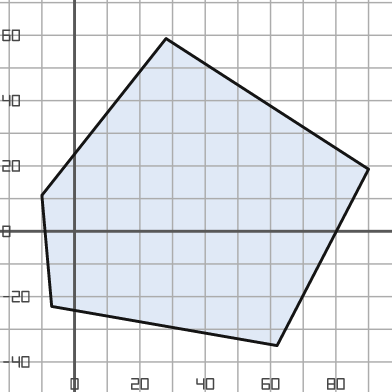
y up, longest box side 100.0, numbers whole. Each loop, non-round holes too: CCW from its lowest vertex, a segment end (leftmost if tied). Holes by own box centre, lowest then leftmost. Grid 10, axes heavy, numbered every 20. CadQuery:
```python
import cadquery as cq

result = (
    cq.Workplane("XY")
    .moveTo(62.0, -35.0)
    .lineTo(90.0, 19.0)
    .lineTo(28.0, 59.0)
    .lineTo(-10.0, 11.0)
    .lineTo(-7.0, -23.0)
    .close()
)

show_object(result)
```